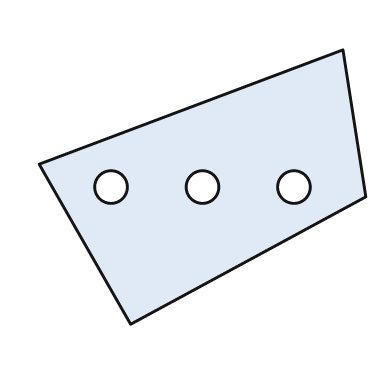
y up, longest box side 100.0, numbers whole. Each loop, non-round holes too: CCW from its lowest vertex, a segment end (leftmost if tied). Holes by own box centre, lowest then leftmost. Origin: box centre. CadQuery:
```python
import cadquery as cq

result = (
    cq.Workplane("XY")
    .moveTo(-22.0, -42.0)
    .lineTo(50.0, -3.0)
    .lineTo(43.0, 42.0)
    .lineTo(-50.0, 7.0)
    .close()
    .moveTo(-28.0, 0.0)
    .circle(5.0)
    .moveTo(0.0, 0.0)
    .circle(5.0)
    .moveTo(28.0, 0.0)
    .circle(5.0)
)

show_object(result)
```